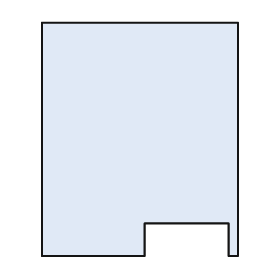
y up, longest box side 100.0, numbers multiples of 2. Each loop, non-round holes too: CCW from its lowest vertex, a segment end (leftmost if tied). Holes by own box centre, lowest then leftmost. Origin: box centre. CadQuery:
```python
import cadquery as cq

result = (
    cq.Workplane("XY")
    .moveTo(-42.0, -50.0)
    .lineTo(2.0, -50.0)
    .lineTo(2.0, -36.0)
    .lineTo(38.0, -36.0)
    .lineTo(38.0, -50.0)
    .lineTo(42.0, -50.0)
    .lineTo(42.0, 50.0)
    .lineTo(-42.0, 50.0)
    .close()
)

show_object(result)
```